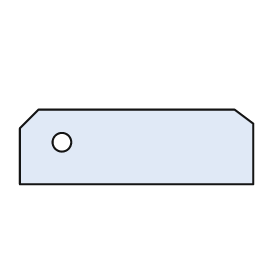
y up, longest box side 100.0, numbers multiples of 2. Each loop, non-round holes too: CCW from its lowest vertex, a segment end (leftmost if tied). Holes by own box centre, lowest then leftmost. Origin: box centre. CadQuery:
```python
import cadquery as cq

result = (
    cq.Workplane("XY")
    .moveTo(-50.0, -16.0)
    .lineTo(50.0, -16.0)
    .lineTo(50.0, 10.0)
    .lineTo(42.0, 16.0)
    .lineTo(-42.0, 16.0)
    .lineTo(-50.0, 8.0)
    .close()
    .moveTo(-32.0, 2.0)
    .circle(4.0)
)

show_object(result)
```